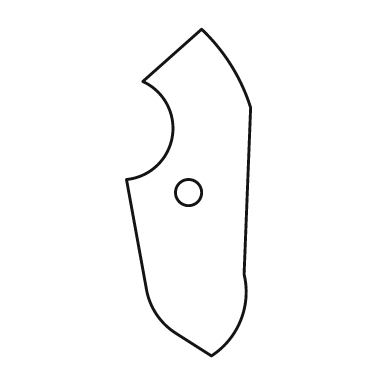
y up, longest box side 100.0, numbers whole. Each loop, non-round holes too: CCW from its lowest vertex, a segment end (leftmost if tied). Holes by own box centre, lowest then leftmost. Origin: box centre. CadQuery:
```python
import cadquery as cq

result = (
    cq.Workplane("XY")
    .moveTo(7.0, -50.0)
    .threePointArc((16.0, -39.0), (17.0, -25.0))
    .lineTo(19.0, 26.0)
    .threePointArc((13.0, 39.0), (4.0, 50.0))
    .lineTo(-14.0, 34.0)
    .threePointArc((-5.0, 17.0), (-19.0, 4.0))
    .lineTo(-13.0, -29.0)
    .threePointArc((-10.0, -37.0), (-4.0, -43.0))
    .close()
    .moveTo(0.0, 0.0)
    .circle(4.0)
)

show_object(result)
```